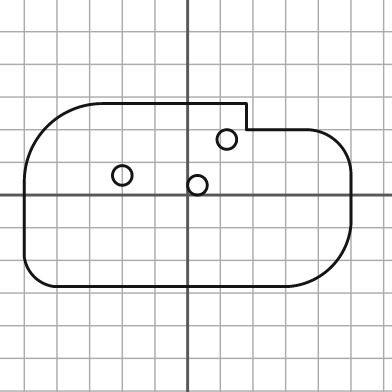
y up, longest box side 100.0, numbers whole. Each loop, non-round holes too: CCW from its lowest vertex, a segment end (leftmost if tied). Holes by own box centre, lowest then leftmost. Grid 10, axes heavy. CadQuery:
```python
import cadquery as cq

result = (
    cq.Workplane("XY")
    .moveTo(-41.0, -28.0)
    .lineTo(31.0, -28.0)
    .threePointArc((44.0, -22.0), (50.0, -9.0))
    .lineTo(50.0, 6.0)
    .threePointArc((46.0, 16.0), (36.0, 20.0))
    .lineTo(18.0, 20.0)
    .lineTo(18.0, 28.0)
    .lineTo(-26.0, 28.0)
    .threePointArc((-43.0, 21.0), (-50.0, 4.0))
    .lineTo(-50.0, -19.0)
    .threePointArc((-47.0, -25.0), (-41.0, -28.0))
    .close()
    .moveTo(3.0, 3.0)
    .circle(3.0)
    .moveTo(-20.0, 6.0)
    .circle(3.0)
    .moveTo(12.0, 17.0)
    .circle(3.0)
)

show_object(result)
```